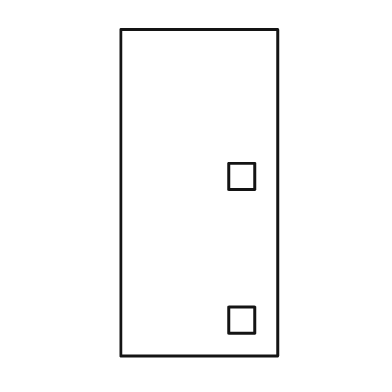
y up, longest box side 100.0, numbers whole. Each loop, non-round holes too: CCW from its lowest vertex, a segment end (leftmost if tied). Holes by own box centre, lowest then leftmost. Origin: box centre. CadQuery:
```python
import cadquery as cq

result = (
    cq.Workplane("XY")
    .moveTo(-24.0, -50.0)
    .lineTo(24.0, -50.0)
    .lineTo(24.0, 50.0)
    .lineTo(-24.0, 50.0)
    .close()
    .moveTo(9.0, -43.0)
    .lineTo(17.0, -43.0)
    .lineTo(17.0, -35.0)
    .lineTo(9.0, -35.0)
    .close()
    .moveTo(9.0, 1.0)
    .lineTo(17.0, 1.0)
    .lineTo(17.0, 9.0)
    .lineTo(9.0, 9.0)
    .close()
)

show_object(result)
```